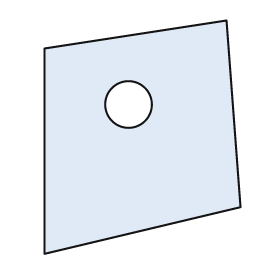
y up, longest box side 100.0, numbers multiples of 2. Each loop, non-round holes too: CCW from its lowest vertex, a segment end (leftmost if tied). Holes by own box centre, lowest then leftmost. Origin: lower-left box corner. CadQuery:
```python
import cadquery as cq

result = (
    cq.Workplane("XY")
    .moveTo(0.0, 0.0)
    .lineTo(84.0, 20.0)
    .lineTo(78.0, 100.0)
    .lineTo(0.0, 88.0)
    .close()
    .moveTo(36.0, 64.0)
    .circle(10.0)
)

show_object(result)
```